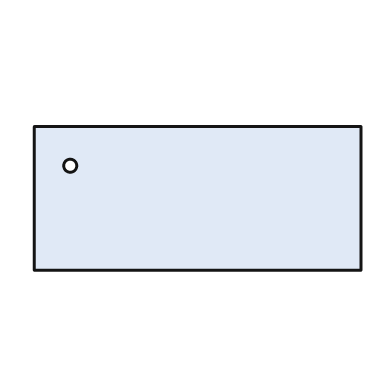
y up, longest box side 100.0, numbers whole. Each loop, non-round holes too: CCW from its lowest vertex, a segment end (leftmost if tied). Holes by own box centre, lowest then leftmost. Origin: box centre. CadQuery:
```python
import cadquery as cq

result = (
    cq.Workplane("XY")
    .moveTo(-50.0, -22.0)
    .lineTo(50.0, -22.0)
    .lineTo(50.0, 22.0)
    .lineTo(-50.0, 22.0)
    .close()
    .moveTo(-39.0, 10.0)
    .circle(2.0)
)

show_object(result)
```